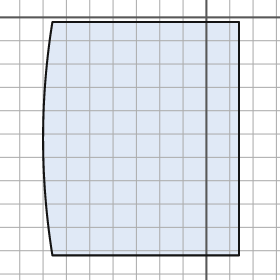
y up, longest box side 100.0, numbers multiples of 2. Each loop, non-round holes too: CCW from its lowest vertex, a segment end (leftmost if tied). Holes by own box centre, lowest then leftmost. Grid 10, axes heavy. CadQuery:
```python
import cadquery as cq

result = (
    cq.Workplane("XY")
    .moveTo(-66.0, -102.0)
    .lineTo(14.0, -102.0)
    .lineTo(14.0, -2.0)
    .lineTo(-66.0, -2.0)
    .threePointArc((-70.0, -52.0), (-66.0, -102.0))
    .close()
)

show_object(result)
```